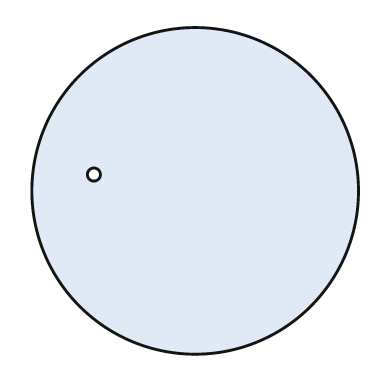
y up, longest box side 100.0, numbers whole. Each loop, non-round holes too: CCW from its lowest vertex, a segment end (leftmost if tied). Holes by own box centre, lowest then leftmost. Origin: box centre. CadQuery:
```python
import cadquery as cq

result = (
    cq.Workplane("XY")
    .moveTo(0.0, 0.0)
    .circle(50.0)
    .moveTo(-31.0, 5.0)
    .circle(2.0)
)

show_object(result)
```